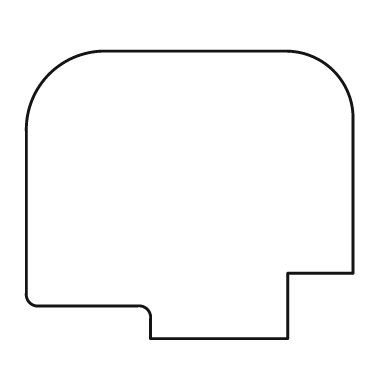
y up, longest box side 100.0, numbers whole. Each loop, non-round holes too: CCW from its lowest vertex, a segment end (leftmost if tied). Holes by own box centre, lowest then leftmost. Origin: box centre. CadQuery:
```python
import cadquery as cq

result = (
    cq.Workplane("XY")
    .moveTo(-12.0, -44.0)
    .lineTo(30.0, -44.0)
    .lineTo(30.0, -24.0)
    .lineTo(50.0, -24.0)
    .lineTo(50.0, 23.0)
    .threePointArc((44.0, 38.0), (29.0, 44.0))
    .lineTo(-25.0, 44.0)
    .threePointArc((-43.0, 37.0), (-50.0, 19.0))
    .lineTo(-50.0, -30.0)
    .threePointArc((-49.0, -33.0), (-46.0, -34.0))
    .lineTo(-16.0, -34.0)
    .threePointArc((-13.0, -35.0), (-12.0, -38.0))
    .close()
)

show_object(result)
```